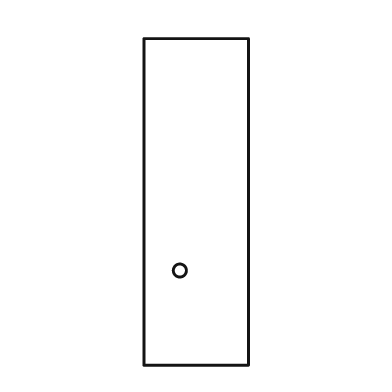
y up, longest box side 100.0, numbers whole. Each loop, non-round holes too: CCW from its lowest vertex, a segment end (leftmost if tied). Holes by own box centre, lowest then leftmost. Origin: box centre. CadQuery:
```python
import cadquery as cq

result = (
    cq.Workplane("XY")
    .moveTo(-16.0, -50.0)
    .lineTo(16.0, -50.0)
    .lineTo(16.0, 50.0)
    .lineTo(-16.0, 50.0)
    .close()
    .moveTo(-5.0, -21.0)
    .circle(2.0)
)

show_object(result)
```